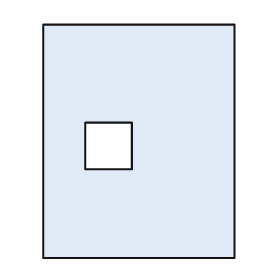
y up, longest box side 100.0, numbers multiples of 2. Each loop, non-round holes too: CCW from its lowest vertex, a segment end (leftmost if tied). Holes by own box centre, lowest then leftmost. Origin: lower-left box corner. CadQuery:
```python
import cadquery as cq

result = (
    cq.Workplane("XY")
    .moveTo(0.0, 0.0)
    .lineTo(82.0, 0.0)
    .lineTo(82.0, 100.0)
    .lineTo(0.0, 100.0)
    .close()
    .moveTo(18.0, 38.0)
    .lineTo(38.0, 38.0)
    .lineTo(38.0, 58.0)
    .lineTo(18.0, 58.0)
    .close()
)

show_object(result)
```